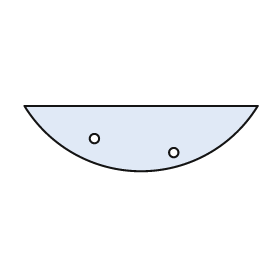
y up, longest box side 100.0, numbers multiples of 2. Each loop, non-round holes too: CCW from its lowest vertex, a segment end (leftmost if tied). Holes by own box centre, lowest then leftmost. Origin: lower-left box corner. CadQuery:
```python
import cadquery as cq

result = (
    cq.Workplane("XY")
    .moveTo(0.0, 28.0)
    .threePointArc((50.0, 0.0), (100.0, 28.0))
    .close()
    .moveTo(64.0, 8.0)
    .circle(2.0)
    .moveTo(30.0, 14.0)
    .circle(2.0)
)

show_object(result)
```